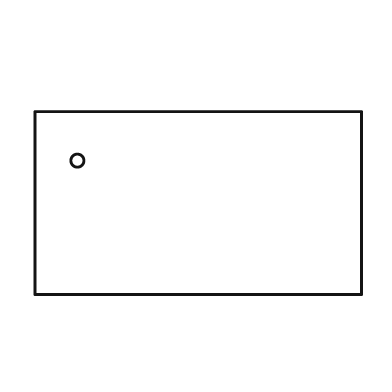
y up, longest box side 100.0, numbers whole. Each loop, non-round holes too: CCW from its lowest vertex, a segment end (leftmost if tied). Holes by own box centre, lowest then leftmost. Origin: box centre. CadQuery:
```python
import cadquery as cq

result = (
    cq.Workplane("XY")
    .moveTo(-50.0, -28.0)
    .lineTo(50.0, -28.0)
    .lineTo(50.0, 28.0)
    .lineTo(-50.0, 28.0)
    .close()
    .moveTo(-37.0, 13.0)
    .circle(2.0)
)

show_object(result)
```